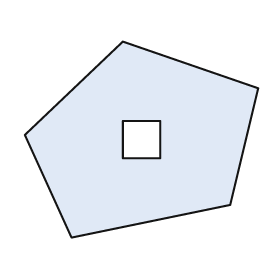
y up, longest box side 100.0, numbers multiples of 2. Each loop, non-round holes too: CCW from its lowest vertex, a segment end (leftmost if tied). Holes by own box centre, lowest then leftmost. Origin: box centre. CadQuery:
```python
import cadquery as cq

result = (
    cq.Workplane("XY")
    .moveTo(-30.0, -42.0)
    .lineTo(38.0, -28.0)
    .lineTo(50.0, 22.0)
    .lineTo(-8.0, 42.0)
    .lineTo(-50.0, 2.0)
    .close()
    .moveTo(-8.0, -8.0)
    .lineTo(8.0, -8.0)
    .lineTo(8.0, 8.0)
    .lineTo(-8.0, 8.0)
    .close()
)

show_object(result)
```